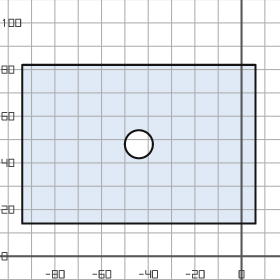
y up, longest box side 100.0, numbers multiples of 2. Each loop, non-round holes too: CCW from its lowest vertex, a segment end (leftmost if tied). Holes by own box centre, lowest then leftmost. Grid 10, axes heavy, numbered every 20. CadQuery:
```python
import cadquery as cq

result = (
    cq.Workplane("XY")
    .moveTo(-94.0, 14.0)
    .lineTo(6.0, 14.0)
    .lineTo(6.0, 82.0)
    .lineTo(-94.0, 82.0)
    .close()
    .moveTo(-44.0, 48.0)
    .circle(6.0)
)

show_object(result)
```